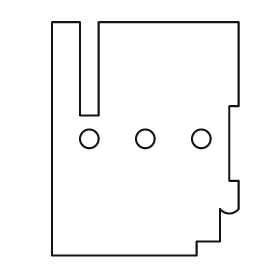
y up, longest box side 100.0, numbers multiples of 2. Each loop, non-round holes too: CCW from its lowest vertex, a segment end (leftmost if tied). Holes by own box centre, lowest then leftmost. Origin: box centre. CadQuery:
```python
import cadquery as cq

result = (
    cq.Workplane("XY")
    .moveTo(-40.0, -50.0)
    .lineTo(22.0, -50.0)
    .lineTo(22.0, -44.0)
    .lineTo(32.0, -44.0)
    .lineTo(32.0, -30.0)
    .threePointArc((36.0, -32.0), (40.0, -30.0))
    .lineTo(40.0, -18.0)
    .lineTo(36.0, -18.0)
    .lineTo(36.0, 14.0)
    .lineTo(40.0, 14.0)
    .lineTo(40.0, 50.0)
    .lineTo(-20.0, 50.0)
    .lineTo(-20.0, 10.0)
    .lineTo(-28.0, 10.0)
    .lineTo(-28.0, 50.0)
    .lineTo(-40.0, 50.0)
    .close()
    .moveTo(-24.0, 0.0)
    .circle(4.0)
    .moveTo(0.0, 0.0)
    .circle(4.0)
    .moveTo(24.0, 0.0)
    .circle(4.0)
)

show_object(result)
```